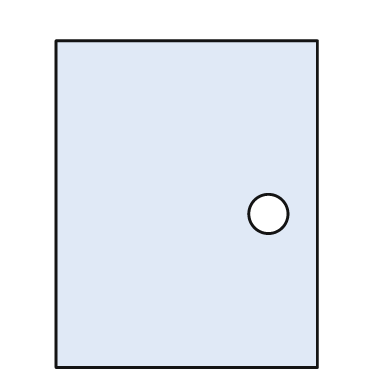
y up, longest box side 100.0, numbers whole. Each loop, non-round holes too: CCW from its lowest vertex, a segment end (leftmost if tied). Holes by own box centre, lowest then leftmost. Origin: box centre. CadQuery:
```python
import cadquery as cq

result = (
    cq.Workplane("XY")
    .moveTo(-40.0, -50.0)
    .lineTo(40.0, -50.0)
    .lineTo(40.0, 50.0)
    .lineTo(-40.0, 50.0)
    .close()
    .moveTo(25.0, -3.0)
    .circle(6.0)
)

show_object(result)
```